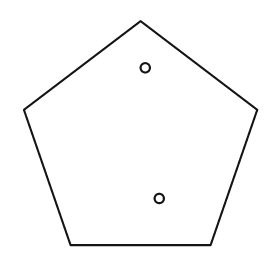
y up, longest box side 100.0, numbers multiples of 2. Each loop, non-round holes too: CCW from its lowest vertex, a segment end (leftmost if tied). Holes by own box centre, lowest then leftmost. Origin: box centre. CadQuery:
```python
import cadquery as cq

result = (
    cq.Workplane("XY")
    .moveTo(-30.0, -48.0)
    .lineTo(30.0, -48.0)
    .lineTo(50.0, 10.0)
    .lineTo(0.0, 48.0)
    .lineTo(-50.0, 10.0)
    .close()
    .moveTo(8.0, -28.0)
    .circle(2.0)
    .moveTo(2.0, 28.0)
    .circle(2.0)
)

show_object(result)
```